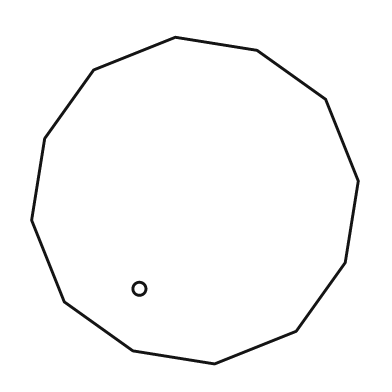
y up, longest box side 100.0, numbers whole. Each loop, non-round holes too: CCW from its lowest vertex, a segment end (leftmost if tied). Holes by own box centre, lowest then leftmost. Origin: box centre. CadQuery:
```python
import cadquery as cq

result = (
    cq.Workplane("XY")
    .moveTo(6.0, -50.0)
    .lineTo(31.0, -40.0)
    .lineTo(46.0, -19.0)
    .lineTo(50.0, 6.0)
    .lineTo(40.0, 31.0)
    .lineTo(19.0, 46.0)
    .lineTo(-6.0, 50.0)
    .lineTo(-31.0, 40.0)
    .lineTo(-46.0, 19.0)
    .lineTo(-50.0, -6.0)
    .lineTo(-40.0, -31.0)
    .lineTo(-19.0, -46.0)
    .close()
    .moveTo(-17.0, -27.0)
    .circle(2.0)
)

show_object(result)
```